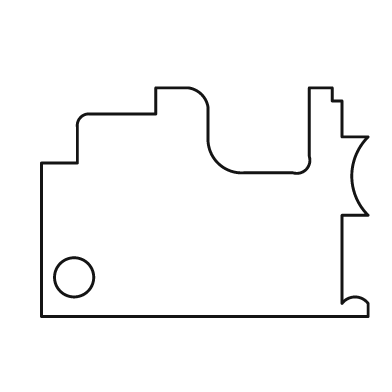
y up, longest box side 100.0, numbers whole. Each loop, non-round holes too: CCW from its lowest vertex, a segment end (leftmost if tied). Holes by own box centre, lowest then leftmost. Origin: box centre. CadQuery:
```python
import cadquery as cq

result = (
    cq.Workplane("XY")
    .moveTo(-50.0, -35.0)
    .lineTo(50.0, -35.0)
    .lineTo(50.0, -31.0)
    .threePointArc((46.0, -29.0), (42.0, -31.0))
    .lineTo(42.0, -4.0)
    .lineTo(50.0, -4.0)
    .threePointArc((45.0, 8.0), (50.0, 20.0))
    .lineTo(42.0, 20.0)
    .lineTo(42.0, 31.0)
    .lineTo(39.0, 31.0)
    .lineTo(39.0, 35.0)
    .lineTo(32.0, 35.0)
    .lineTo(32.0, 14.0)
    .threePointArc((31.0, 10.0), (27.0, 9.0))
    .lineTo(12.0, 9.0)
    .threePointArc((4.0, 12.0), (1.0, 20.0))
    .lineTo(1.0, 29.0)
    .threePointArc((-1.0, 33.0), (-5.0, 35.0))
    .lineTo(-15.0, 35.0)
    .lineTo(-15.0, 27.0)
    .lineTo(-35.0, 27.0)
    .threePointArc((-38.0, 26.0), (-39.0, 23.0))
    .lineTo(-39.0, 12.0)
    .lineTo(-50.0, 12.0)
    .close()
    .moveTo(-40.0, -23.0)
    .circle(6.0)
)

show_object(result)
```